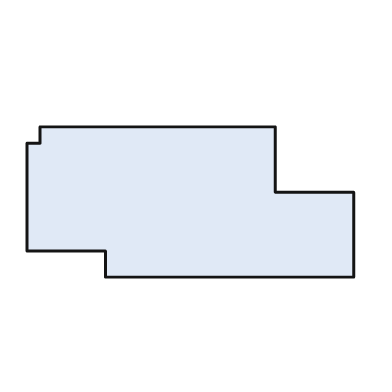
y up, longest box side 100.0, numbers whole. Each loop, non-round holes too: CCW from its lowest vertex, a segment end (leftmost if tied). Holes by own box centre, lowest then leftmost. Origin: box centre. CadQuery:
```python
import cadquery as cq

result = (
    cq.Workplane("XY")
    .moveTo(-26.0, -23.0)
    .lineTo(50.0, -23.0)
    .lineTo(50.0, 3.0)
    .lineTo(26.0, 3.0)
    .lineTo(26.0, 23.0)
    .lineTo(-46.0, 23.0)
    .lineTo(-46.0, 18.0)
    .lineTo(-50.0, 18.0)
    .lineTo(-50.0, -15.0)
    .lineTo(-26.0, -15.0)
    .close()
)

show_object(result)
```